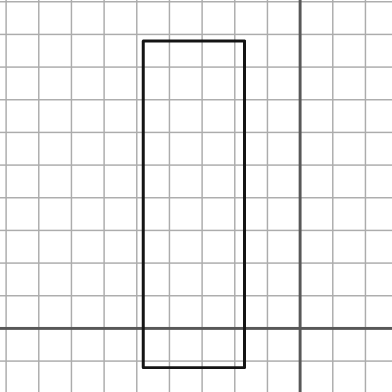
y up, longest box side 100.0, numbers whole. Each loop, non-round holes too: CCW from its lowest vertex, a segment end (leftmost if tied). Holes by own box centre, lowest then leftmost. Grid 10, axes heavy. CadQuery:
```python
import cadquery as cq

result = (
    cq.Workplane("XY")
    .moveTo(-48.0, -12.0)
    .lineTo(-17.0, -12.0)
    .lineTo(-17.0, 88.0)
    .lineTo(-48.0, 88.0)
    .close()
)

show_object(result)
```